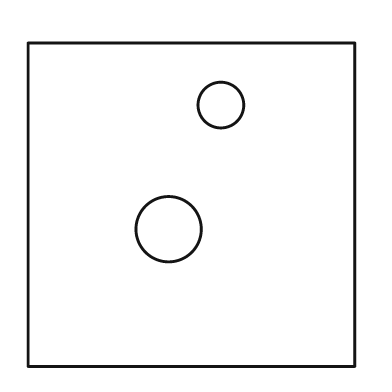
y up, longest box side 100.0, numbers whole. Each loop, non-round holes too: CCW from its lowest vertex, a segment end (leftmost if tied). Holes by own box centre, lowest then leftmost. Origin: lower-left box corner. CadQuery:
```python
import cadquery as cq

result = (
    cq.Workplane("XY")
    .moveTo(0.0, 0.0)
    .lineTo(100.0, 0.0)
    .lineTo(100.0, 99.0)
    .lineTo(0.0, 99.0)
    .close()
    .moveTo(43.0, 42.0)
    .circle(10.0)
    .moveTo(59.0, 80.0)
    .circle(7.0)
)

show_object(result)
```